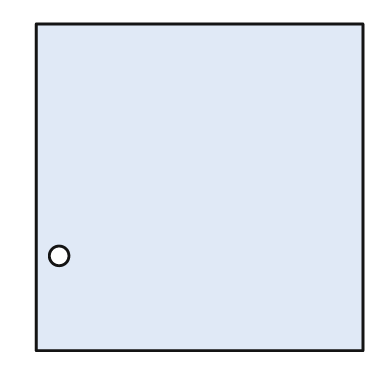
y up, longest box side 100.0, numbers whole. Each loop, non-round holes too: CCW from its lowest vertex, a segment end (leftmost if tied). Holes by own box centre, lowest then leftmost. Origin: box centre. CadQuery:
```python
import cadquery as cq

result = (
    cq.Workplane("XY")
    .moveTo(-50.0, -50.0)
    .lineTo(50.0, -50.0)
    .lineTo(50.0, 50.0)
    .lineTo(-50.0, 50.0)
    .close()
    .moveTo(-43.0, -21.0)
    .circle(3.0)
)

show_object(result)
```